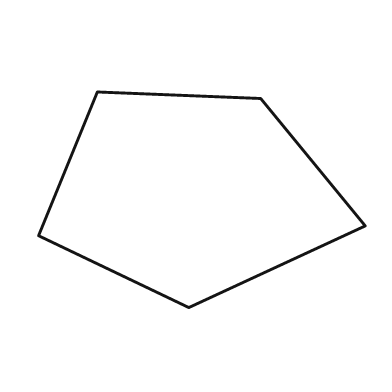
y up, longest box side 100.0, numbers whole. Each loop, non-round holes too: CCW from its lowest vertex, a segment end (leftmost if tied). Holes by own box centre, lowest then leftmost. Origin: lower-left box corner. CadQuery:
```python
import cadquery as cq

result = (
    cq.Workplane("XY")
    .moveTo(46.0, 0.0)
    .lineTo(100.0, 25.0)
    .lineTo(68.0, 64.0)
    .lineTo(18.0, 66.0)
    .lineTo(0.0, 22.0)
    .close()
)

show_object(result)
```